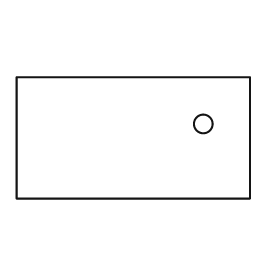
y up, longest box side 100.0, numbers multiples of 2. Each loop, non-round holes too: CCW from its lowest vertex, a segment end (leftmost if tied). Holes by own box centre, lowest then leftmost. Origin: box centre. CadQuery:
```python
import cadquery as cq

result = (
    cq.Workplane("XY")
    .moveTo(-50.0, -26.0)
    .lineTo(50.0, -26.0)
    .lineTo(50.0, 26.0)
    .lineTo(-50.0, 26.0)
    .close()
    .moveTo(30.0, 6.0)
    .circle(4.0)
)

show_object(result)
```